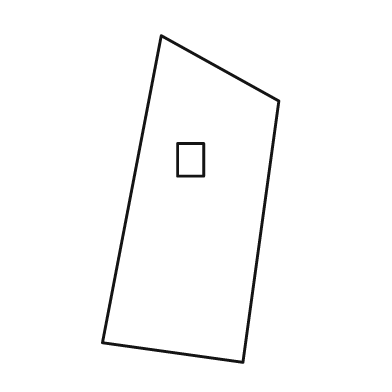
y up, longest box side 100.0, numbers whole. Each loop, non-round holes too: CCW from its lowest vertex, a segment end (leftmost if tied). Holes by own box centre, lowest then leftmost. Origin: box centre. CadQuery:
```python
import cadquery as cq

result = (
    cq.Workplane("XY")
    .moveTo(16.0, -50.0)
    .lineTo(27.0, 30.0)
    .lineTo(-9.0, 50.0)
    .lineTo(-27.0, -44.0)
    .close()
    .moveTo(-4.0, 7.0)
    .lineTo(4.0, 7.0)
    .lineTo(4.0, 17.0)
    .lineTo(-4.0, 17.0)
    .close()
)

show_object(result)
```